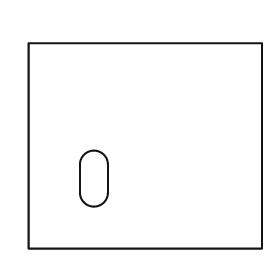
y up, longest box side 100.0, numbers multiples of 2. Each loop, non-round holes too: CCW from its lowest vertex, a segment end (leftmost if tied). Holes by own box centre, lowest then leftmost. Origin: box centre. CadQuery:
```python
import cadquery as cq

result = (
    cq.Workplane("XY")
    .moveTo(-50.0, -44.0)
    .lineTo(50.0, -44.0)
    .lineTo(50.0, 44.0)
    .lineTo(-50.0, 44.0)
    .close()
    .moveTo(-28.0, -20.0)
    .threePointArc((-22.0, -26.0), (-16.0, -20.0))
    .lineTo(-16.0, -8.0)
    .threePointArc((-22.0, -2.0), (-28.0, -8.0))
    .close()
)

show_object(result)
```